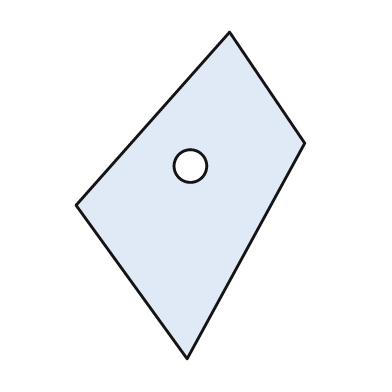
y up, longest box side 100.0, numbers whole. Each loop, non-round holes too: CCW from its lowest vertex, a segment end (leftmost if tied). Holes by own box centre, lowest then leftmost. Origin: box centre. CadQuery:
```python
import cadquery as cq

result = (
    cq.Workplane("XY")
    .moveTo(-1.0, -50.0)
    .lineTo(35.0, 16.0)
    .lineTo(12.0, 50.0)
    .lineTo(-35.0, -3.0)
    .close()
    .moveTo(0.0, 9.0)
    .circle(5.0)
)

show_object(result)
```